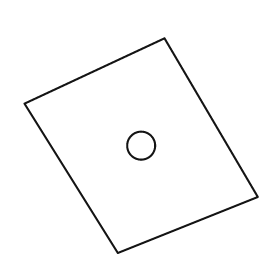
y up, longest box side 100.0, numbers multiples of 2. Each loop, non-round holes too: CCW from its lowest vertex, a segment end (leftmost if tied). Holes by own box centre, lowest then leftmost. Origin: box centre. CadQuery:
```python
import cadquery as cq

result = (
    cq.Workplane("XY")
    .moveTo(-10.0, -46.0)
    .lineTo(50.0, -22.0)
    .lineTo(10.0, 46.0)
    .lineTo(-50.0, 18.0)
    .close()
    .moveTo(0.0, 0.0)
    .circle(6.0)
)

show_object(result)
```